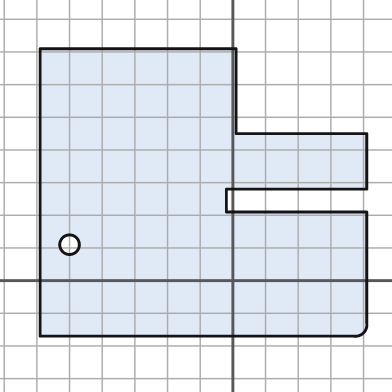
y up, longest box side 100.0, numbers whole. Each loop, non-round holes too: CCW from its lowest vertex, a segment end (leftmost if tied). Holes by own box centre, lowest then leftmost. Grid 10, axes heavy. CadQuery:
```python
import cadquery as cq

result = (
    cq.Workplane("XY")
    .moveTo(-59.0, -17.0)
    .lineTo(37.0, -17.0)
    .threePointArc((40.0, -16.0), (41.0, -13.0))
    .lineTo(41.0, 21.0)
    .lineTo(-2.0, 21.0)
    .lineTo(-2.0, 28.0)
    .lineTo(41.0, 28.0)
    .lineTo(41.0, 45.0)
    .lineTo(1.0, 45.0)
    .lineTo(1.0, 71.0)
    .lineTo(-59.0, 71.0)
    .close()
    .moveTo(-50.0, 11.0)
    .circle(3.0)
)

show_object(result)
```